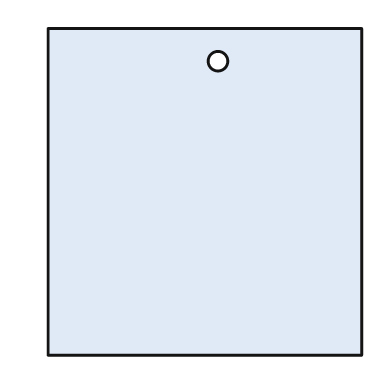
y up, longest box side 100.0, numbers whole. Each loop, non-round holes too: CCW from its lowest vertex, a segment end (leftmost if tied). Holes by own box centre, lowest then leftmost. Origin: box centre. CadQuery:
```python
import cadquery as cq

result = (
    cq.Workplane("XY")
    .moveTo(-48.0, -50.0)
    .lineTo(48.0, -50.0)
    .lineTo(48.0, 50.0)
    .lineTo(-48.0, 50.0)
    .close()
    .moveTo(4.0, 40.0)
    .circle(3.0)
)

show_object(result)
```